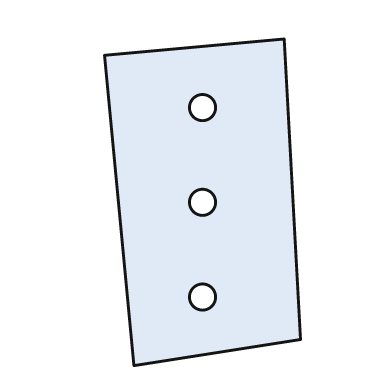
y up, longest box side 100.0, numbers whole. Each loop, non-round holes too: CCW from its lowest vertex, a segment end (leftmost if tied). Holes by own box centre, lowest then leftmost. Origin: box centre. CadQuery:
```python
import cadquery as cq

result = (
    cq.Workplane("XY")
    .moveTo(-21.0, -50.0)
    .lineTo(30.0, -42.0)
    .lineTo(25.0, 50.0)
    .lineTo(-30.0, 45.0)
    .close()
    .moveTo(0.0, -29.0)
    .circle(4.0)
    .moveTo(0.0, 0.0)
    .circle(4.0)
    .moveTo(0.0, 29.0)
    .circle(4.0)
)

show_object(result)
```